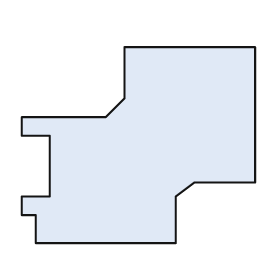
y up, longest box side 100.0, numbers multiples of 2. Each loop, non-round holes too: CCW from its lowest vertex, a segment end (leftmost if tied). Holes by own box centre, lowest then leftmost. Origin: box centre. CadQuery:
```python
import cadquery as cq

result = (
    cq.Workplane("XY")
    .moveTo(-44.0, -42.0)
    .lineTo(16.0, -42.0)
    .lineTo(16.0, -22.0)
    .lineTo(24.0, -16.0)
    .lineTo(50.0, -16.0)
    .lineTo(50.0, 42.0)
    .lineTo(-6.0, 42.0)
    .lineTo(-6.0, 20.0)
    .lineTo(-14.0, 12.0)
    .lineTo(-50.0, 12.0)
    .lineTo(-50.0, 4.0)
    .lineTo(-38.0, 4.0)
    .lineTo(-38.0, -22.0)
    .lineTo(-50.0, -22.0)
    .lineTo(-50.0, -30.0)
    .lineTo(-44.0, -30.0)
    .close()
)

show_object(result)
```